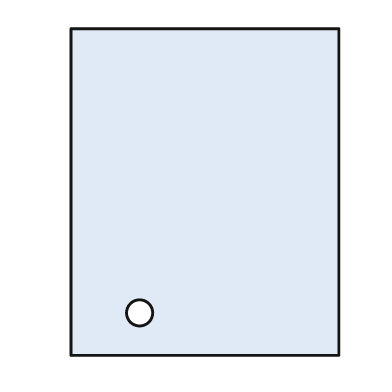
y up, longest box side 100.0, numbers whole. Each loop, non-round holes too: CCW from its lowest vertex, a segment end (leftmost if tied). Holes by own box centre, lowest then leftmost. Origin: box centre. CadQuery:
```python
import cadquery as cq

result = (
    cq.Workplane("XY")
    .moveTo(-41.0, -50.0)
    .lineTo(41.0, -50.0)
    .lineTo(41.0, 50.0)
    .lineTo(-41.0, 50.0)
    .close()
    .moveTo(-20.0, -37.0)
    .circle(4.0)
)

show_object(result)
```